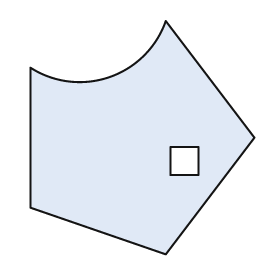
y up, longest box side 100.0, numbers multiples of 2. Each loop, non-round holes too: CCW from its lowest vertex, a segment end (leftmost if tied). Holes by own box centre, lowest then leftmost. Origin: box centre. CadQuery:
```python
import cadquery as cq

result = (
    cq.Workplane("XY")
    .moveTo(10.0, -50.0)
    .lineTo(48.0, 0.0)
    .lineTo(10.0, 50.0)
    .threePointArc((-14.0, 26.0), (-48.0, 30.0))
    .lineTo(-48.0, -30.0)
    .close()
    .moveTo(12.0, -16.0)
    .lineTo(24.0, -16.0)
    .lineTo(24.0, -4.0)
    .lineTo(12.0, -4.0)
    .close()
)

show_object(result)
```